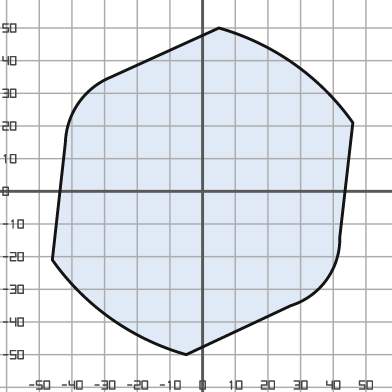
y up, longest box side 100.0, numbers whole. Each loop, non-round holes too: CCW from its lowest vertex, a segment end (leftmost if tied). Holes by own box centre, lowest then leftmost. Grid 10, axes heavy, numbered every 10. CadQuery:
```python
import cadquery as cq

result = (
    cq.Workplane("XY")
    .moveTo(-5.0, -50.0)
    .lineTo(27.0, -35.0)
    .threePointArc((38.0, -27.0), (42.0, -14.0))
    .lineTo(46.0, 21.0)
    .threePointArc((28.0, 39.0), (5.0, 50.0))
    .lineTo(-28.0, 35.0)
    .threePointArc((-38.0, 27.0), (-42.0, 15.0))
    .lineTo(-46.0, -21.0)
    .threePointArc((-28.0, -39.0), (-5.0, -50.0))
    .close()
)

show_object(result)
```